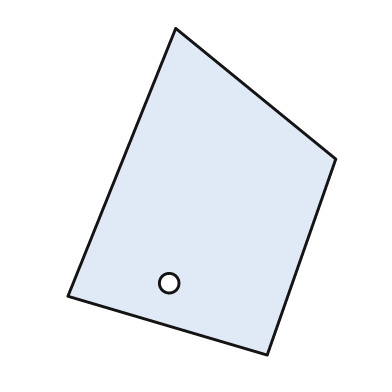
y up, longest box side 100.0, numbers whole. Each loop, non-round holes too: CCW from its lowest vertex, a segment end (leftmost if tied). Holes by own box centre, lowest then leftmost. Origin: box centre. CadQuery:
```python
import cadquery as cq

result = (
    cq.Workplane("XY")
    .moveTo(20.0, -50.0)
    .lineTo(41.0, 10.0)
    .lineTo(-8.0, 50.0)
    .lineTo(-41.0, -32.0)
    .close()
    .moveTo(-10.0, -28.0)
    .circle(3.0)
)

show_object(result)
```